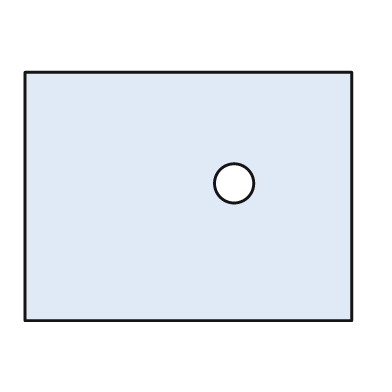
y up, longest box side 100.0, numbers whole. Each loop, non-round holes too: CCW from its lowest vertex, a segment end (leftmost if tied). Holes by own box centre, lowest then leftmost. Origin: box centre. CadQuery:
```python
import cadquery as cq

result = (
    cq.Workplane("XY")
    .moveTo(-50.0, -38.0)
    .lineTo(50.0, -38.0)
    .lineTo(50.0, 38.0)
    .lineTo(-50.0, 38.0)
    .close()
    .moveTo(14.0, 4.0)
    .circle(6.0)
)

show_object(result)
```